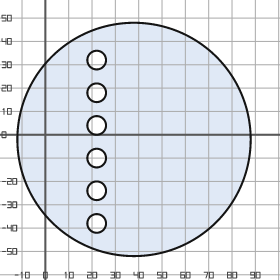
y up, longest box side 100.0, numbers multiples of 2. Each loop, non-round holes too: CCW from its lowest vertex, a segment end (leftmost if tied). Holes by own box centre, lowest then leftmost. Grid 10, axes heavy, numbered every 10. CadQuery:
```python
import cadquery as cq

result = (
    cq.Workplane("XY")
    .moveTo(38.0, -2.0)
    .circle(50.0)
    .moveTo(22.0, -38.0)
    .circle(4.0)
    .moveTo(22.0, -24.0)
    .circle(4.0)
    .moveTo(22.0, -10.0)
    .circle(4.0)
    .moveTo(22.0, 4.0)
    .circle(4.0)
    .moveTo(22.0, 18.0)
    .circle(4.0)
    .moveTo(22.0, 32.0)
    .circle(4.0)
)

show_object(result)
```